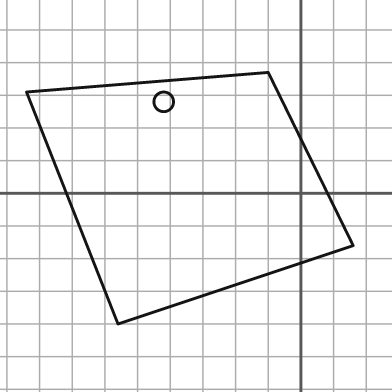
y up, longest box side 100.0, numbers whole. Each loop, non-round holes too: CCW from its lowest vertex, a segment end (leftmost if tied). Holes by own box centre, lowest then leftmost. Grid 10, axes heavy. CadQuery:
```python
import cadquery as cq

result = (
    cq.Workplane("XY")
    .moveTo(-56.0, -40.0)
    .lineTo(16.0, -16.0)
    .lineTo(-10.0, 37.0)
    .lineTo(-84.0, 31.0)
    .close()
    .moveTo(-42.0, 28.0)
    .circle(3.0)
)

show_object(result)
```